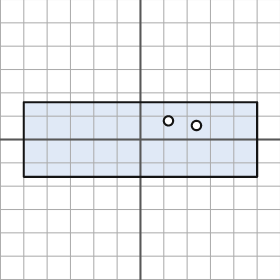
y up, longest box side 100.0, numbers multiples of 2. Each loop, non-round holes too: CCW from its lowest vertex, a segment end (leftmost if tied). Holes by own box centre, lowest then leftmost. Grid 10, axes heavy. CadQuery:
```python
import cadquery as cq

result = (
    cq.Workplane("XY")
    .moveTo(-50.0, -16.0)
    .lineTo(50.0, -16.0)
    .lineTo(50.0, 16.0)
    .lineTo(-50.0, 16.0)
    .close()
    .moveTo(24.0, 6.0)
    .circle(2.0)
    .moveTo(12.0, 8.0)
    .circle(2.0)
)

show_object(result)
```